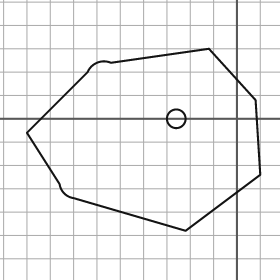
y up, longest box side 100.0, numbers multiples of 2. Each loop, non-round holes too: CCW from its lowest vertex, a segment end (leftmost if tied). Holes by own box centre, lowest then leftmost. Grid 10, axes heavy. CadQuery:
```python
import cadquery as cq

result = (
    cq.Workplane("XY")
    .moveTo(-22.0, -48.0)
    .lineTo(10.0, -24.0)
    .lineTo(8.0, 8.0)
    .lineTo(-12.0, 30.0)
    .lineTo(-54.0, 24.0)
    .threePointArc((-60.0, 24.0), (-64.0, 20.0))
    .lineTo(-90.0, -6.0)
    .lineTo(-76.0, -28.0)
    .threePointArc((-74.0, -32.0), (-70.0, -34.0))
    .close()
    .moveTo(-26.0, 0.0)
    .circle(4.0)
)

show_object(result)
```